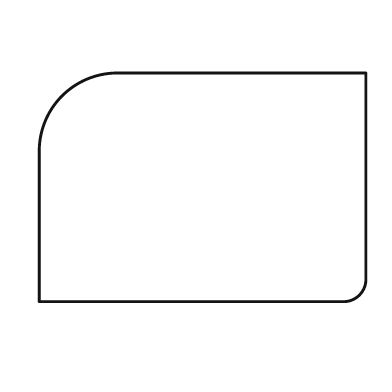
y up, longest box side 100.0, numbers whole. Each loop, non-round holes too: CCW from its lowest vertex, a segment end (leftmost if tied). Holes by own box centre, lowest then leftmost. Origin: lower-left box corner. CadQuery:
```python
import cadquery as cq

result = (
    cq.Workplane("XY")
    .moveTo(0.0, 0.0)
    .lineTo(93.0, 0.0)
    .threePointArc((98.0, 2.0), (100.0, 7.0))
    .lineTo(100.0, 70.0)
    .lineTo(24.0, 70.0)
    .threePointArc((7.0, 63.0), (0.0, 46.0))
    .close()
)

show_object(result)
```